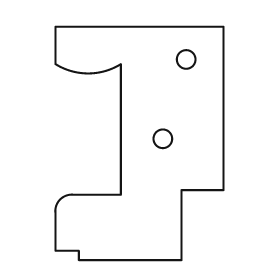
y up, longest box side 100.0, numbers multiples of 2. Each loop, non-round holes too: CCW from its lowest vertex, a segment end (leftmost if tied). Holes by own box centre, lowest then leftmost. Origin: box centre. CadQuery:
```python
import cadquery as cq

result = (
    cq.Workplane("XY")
    .moveTo(-26.0, -50.0)
    .lineTo(18.0, -50.0)
    .lineTo(18.0, -20.0)
    .lineTo(36.0, -20.0)
    .lineTo(36.0, 50.0)
    .lineTo(-36.0, 50.0)
    .lineTo(-36.0, 34.0)
    .threePointArc((-22.0, 30.0), (-8.0, 34.0))
    .lineTo(-8.0, -22.0)
    .lineTo(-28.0, -22.0)
    .threePointArc((-34.0, -24.0), (-36.0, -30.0))
    .lineTo(-36.0, -46.0)
    .lineTo(-26.0, -46.0)
    .close()
    .moveTo(10.0, 2.0)
    .circle(4.0)
    .moveTo(20.0, 36.0)
    .circle(4.0)
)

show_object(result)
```